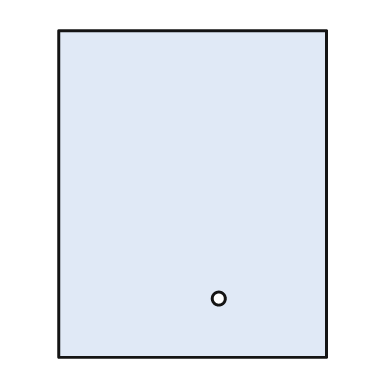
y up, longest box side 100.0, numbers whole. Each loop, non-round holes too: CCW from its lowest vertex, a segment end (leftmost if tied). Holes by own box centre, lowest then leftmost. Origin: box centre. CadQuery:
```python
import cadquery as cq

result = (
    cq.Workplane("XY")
    .moveTo(-41.0, -50.0)
    .lineTo(41.0, -50.0)
    .lineTo(41.0, 50.0)
    .lineTo(-41.0, 50.0)
    .close()
    .moveTo(8.0, -32.0)
    .circle(2.0)
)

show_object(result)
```